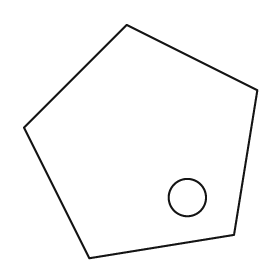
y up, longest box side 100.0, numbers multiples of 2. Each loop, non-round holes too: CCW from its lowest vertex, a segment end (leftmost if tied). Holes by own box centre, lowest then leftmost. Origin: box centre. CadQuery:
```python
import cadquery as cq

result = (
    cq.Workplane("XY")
    .moveTo(-22.0, -50.0)
    .lineTo(40.0, -40.0)
    .lineTo(50.0, 22.0)
    .lineTo(-6.0, 50.0)
    .lineTo(-50.0, 6.0)
    .close()
    .moveTo(20.0, -24.0)
    .circle(8.0)
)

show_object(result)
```